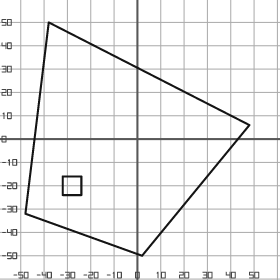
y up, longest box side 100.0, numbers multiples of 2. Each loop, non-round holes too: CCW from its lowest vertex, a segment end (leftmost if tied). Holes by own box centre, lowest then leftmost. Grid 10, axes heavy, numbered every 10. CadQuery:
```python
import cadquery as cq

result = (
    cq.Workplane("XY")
    .moveTo(2.0, -50.0)
    .lineTo(48.0, 6.0)
    .lineTo(-38.0, 50.0)
    .lineTo(-48.0, -32.0)
    .close()
    .moveTo(-32.0, -24.0)
    .lineTo(-24.0, -24.0)
    .lineTo(-24.0, -16.0)
    .lineTo(-32.0, -16.0)
    .close()
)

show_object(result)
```